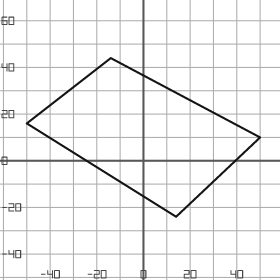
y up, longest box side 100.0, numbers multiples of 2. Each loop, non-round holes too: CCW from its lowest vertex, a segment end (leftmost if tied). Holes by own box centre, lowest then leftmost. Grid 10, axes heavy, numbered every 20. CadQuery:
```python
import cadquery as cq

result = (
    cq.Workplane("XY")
    .moveTo(14.0, -24.0)
    .lineTo(50.0, 10.0)
    .lineTo(-14.0, 44.0)
    .lineTo(-50.0, 16.0)
    .close()
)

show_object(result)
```